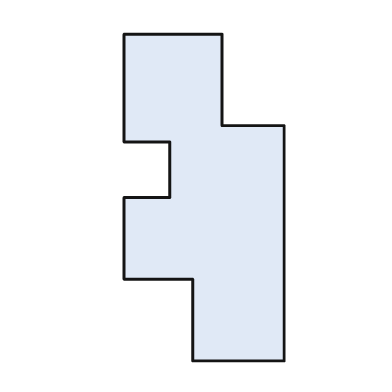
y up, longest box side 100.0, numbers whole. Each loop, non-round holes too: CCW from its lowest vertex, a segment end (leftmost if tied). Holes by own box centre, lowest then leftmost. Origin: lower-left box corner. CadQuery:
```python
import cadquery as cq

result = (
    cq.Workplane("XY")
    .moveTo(21.0, 0.0)
    .lineTo(49.0, 0.0)
    .lineTo(49.0, 72.0)
    .lineTo(30.0, 72.0)
    .lineTo(30.0, 100.0)
    .lineTo(0.0, 100.0)
    .lineTo(0.0, 67.0)
    .lineTo(14.0, 67.0)
    .lineTo(14.0, 50.0)
    .lineTo(0.0, 50.0)
    .lineTo(0.0, 25.0)
    .lineTo(21.0, 25.0)
    .close()
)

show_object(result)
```